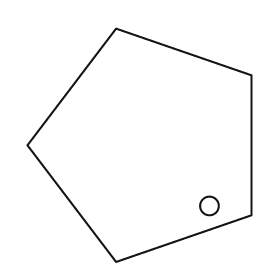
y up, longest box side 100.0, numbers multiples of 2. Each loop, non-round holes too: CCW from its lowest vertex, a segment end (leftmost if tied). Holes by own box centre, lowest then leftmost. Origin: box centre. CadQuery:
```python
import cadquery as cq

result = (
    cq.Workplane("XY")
    .moveTo(-10.0, -50.0)
    .lineTo(48.0, -30.0)
    .lineTo(48.0, 30.0)
    .lineTo(-10.0, 50.0)
    .lineTo(-48.0, 0.0)
    .close()
    .moveTo(30.0, -26.0)
    .circle(4.0)
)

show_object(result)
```